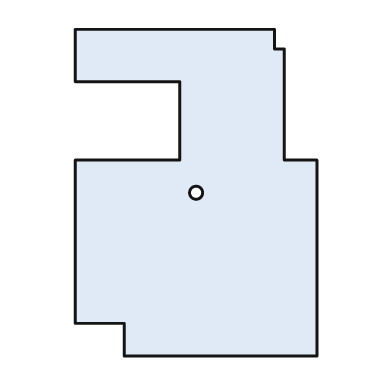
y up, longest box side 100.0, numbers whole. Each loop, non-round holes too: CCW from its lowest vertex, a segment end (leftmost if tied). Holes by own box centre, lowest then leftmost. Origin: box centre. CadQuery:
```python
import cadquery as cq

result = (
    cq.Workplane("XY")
    .moveTo(-22.0, -50.0)
    .lineTo(37.0, -50.0)
    .lineTo(37.0, 10.0)
    .lineTo(27.0, 10.0)
    .lineTo(27.0, 44.0)
    .lineTo(24.0, 44.0)
    .lineTo(24.0, 50.0)
    .lineTo(-37.0, 50.0)
    .lineTo(-37.0, 34.0)
    .lineTo(-5.0, 34.0)
    .lineTo(-5.0, 10.0)
    .lineTo(-37.0, 10.0)
    .lineTo(-37.0, -40.0)
    .lineTo(-22.0, -40.0)
    .close()
    .moveTo(0.0, 0.0)
    .circle(2.0)
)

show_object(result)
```